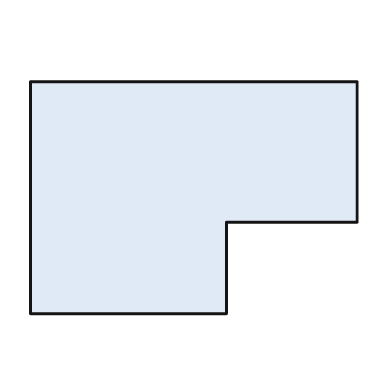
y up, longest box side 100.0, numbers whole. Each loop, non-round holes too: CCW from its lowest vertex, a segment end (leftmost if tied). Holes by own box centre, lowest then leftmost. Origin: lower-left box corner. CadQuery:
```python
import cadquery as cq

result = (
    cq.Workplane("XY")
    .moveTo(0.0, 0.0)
    .lineTo(60.0, 0.0)
    .lineTo(60.0, 28.0)
    .lineTo(100.0, 28.0)
    .lineTo(100.0, 71.0)
    .lineTo(0.0, 71.0)
    .close()
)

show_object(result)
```